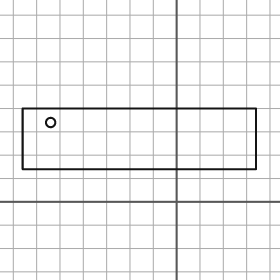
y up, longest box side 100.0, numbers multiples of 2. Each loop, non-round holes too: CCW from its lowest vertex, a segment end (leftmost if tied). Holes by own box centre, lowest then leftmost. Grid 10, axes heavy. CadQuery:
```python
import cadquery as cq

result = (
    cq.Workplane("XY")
    .moveTo(-66.0, 14.0)
    .lineTo(34.0, 14.0)
    .lineTo(34.0, 40.0)
    .lineTo(-66.0, 40.0)
    .close()
    .moveTo(-54.0, 34.0)
    .circle(2.0)
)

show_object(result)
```